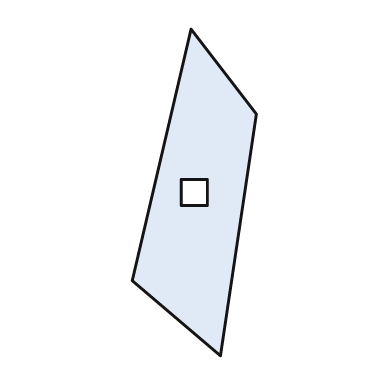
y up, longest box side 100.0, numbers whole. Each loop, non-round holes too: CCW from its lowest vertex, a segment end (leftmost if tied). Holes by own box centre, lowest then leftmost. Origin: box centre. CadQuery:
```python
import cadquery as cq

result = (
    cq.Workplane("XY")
    .moveTo(8.0, -50.0)
    .lineTo(19.0, 24.0)
    .lineTo(-1.0, 50.0)
    .lineTo(-19.0, -27.0)
    .close()
    .moveTo(-4.0, -4.0)
    .lineTo(4.0, -4.0)
    .lineTo(4.0, 4.0)
    .lineTo(-4.0, 4.0)
    .close()
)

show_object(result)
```